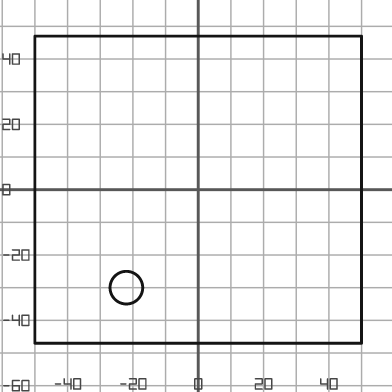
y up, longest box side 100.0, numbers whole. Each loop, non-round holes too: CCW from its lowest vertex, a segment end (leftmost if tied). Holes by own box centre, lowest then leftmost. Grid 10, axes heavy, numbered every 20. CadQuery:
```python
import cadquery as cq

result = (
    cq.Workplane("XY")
    .moveTo(-50.0, -47.0)
    .lineTo(50.0, -47.0)
    .lineTo(50.0, 47.0)
    .lineTo(-50.0, 47.0)
    .close()
    .moveTo(-22.0, -30.0)
    .circle(5.0)
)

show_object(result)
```